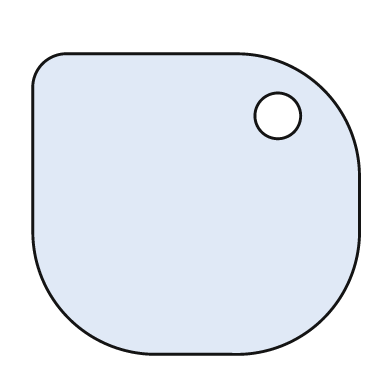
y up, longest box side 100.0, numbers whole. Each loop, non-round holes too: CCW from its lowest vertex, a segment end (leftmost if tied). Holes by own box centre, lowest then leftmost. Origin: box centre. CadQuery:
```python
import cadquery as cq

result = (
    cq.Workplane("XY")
    .moveTo(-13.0, -46.0)
    .lineTo(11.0, -46.0)
    .threePointArc((39.0, -35.0), (50.0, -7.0))
    .lineTo(50.0, 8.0)
    .threePointArc((39.0, 35.0), (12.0, 46.0))
    .lineTo(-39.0, 46.0)
    .threePointArc((-47.0, 43.0), (-50.0, 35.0))
    .lineTo(-50.0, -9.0)
    .threePointArc((-39.0, -35.0), (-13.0, -46.0))
    .close()
    .moveTo(25.0, 27.0)
    .circle(7.0)
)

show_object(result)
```